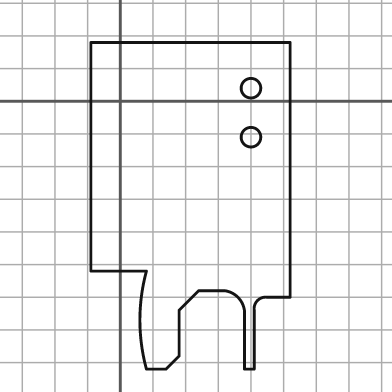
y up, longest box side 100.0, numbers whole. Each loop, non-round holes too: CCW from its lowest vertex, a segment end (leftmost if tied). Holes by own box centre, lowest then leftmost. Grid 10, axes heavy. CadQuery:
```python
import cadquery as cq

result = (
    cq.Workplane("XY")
    .moveTo(8.0, -82.0)
    .lineTo(14.0, -82.0)
    .lineTo(18.0, -78.0)
    .lineTo(18.0, -64.0)
    .lineTo(24.0, -58.0)
    .lineTo(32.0, -58.0)
    .threePointArc((36.0, -60.0), (38.0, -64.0))
    .lineTo(38.0, -82.0)
    .lineTo(41.0, -82.0)
    .lineTo(41.0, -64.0)
    .threePointArc((42.0, -61.0), (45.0, -60.0))
    .lineTo(52.0, -60.0)
    .lineTo(52.0, 18.0)
    .lineTo(-9.0, 18.0)
    .lineTo(-9.0, -52.0)
    .lineTo(8.0, -52.0)
    .threePointArc((6.0, -67.0), (8.0, -82.0))
    .close()
    .moveTo(40.0, -11.0)
    .circle(3.0)
    .moveTo(40.0, 4.0)
    .circle(3.0)
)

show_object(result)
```